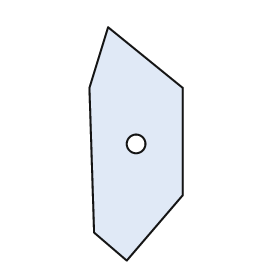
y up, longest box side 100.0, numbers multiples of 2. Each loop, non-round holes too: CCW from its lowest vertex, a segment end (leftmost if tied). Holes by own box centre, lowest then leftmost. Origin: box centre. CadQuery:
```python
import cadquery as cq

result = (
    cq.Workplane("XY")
    .moveTo(-4.0, -50.0)
    .lineTo(20.0, -22.0)
    .lineTo(20.0, 24.0)
    .lineTo(-12.0, 50.0)
    .lineTo(-20.0, 24.0)
    .lineTo(-18.0, -38.0)
    .close()
    .moveTo(0.0, 0.0)
    .circle(4.0)
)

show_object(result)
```